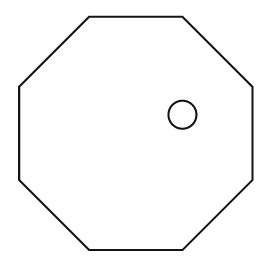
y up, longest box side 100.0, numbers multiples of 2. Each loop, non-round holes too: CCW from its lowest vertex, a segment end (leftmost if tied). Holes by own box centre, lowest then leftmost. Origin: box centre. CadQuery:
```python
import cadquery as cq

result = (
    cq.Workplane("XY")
    .moveTo(-20.0, -50.0)
    .lineTo(20.0, -50.0)
    .lineTo(50.0, -20.0)
    .lineTo(50.0, 20.0)
    .lineTo(20.0, 50.0)
    .lineTo(-20.0, 50.0)
    .lineTo(-50.0, 20.0)
    .lineTo(-50.0, -20.0)
    .close()
    .moveTo(20.0, 8.0)
    .circle(6.0)
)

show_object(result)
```